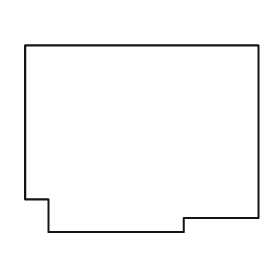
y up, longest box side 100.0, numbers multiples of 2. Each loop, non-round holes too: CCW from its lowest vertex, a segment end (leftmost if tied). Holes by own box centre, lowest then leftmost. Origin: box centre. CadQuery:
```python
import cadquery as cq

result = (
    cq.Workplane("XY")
    .moveTo(-40.0, -40.0)
    .lineTo(18.0, -40.0)
    .lineTo(18.0, -34.0)
    .lineTo(50.0, -34.0)
    .lineTo(50.0, 40.0)
    .lineTo(-50.0, 40.0)
    .lineTo(-50.0, -26.0)
    .lineTo(-40.0, -26.0)
    .close()
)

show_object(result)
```